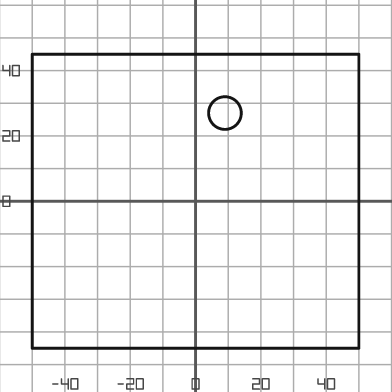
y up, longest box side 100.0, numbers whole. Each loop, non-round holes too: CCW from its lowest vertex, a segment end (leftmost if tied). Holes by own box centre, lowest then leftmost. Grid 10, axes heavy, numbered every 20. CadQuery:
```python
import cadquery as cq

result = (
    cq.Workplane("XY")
    .moveTo(-50.0, -45.0)
    .lineTo(50.0, -45.0)
    .lineTo(50.0, 45.0)
    .lineTo(-50.0, 45.0)
    .close()
    .moveTo(9.0, 27.0)
    .circle(5.0)
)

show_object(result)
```